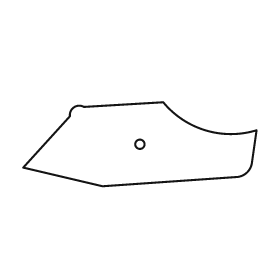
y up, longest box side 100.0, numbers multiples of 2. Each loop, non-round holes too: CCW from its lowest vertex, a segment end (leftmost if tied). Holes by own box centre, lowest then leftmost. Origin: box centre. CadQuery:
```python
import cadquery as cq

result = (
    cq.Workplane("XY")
    .moveTo(-16.0, -18.0)
    .lineTo(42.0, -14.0)
    .threePointArc((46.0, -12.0), (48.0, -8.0))
    .lineTo(50.0, 6.0)
    .threePointArc((28.0, 6.0), (10.0, 18.0))
    .lineTo(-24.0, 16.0)
    .threePointArc((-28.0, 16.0), (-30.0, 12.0))
    .lineTo(-50.0, -10.0)
    .close()
    .moveTo(0.0, 0.0)
    .circle(2.0)
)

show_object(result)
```